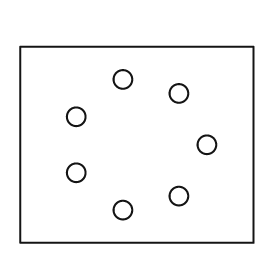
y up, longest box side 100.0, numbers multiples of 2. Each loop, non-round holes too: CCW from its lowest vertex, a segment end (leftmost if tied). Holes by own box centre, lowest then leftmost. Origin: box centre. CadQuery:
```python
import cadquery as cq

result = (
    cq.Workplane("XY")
    .moveTo(-50.0, -42.0)
    .lineTo(50.0, -42.0)
    .lineTo(50.0, 42.0)
    .lineTo(-50.0, 42.0)
    .close()
    .moveTo(-6.0, -28.0)
    .circle(4.0)
    .moveTo(18.0, -22.0)
    .circle(4.0)
    .moveTo(-26.0, -12.0)
    .circle(4.0)
    .moveTo(30.0, 0.0)
    .circle(4.0)
    .moveTo(-26.0, 12.0)
    .circle(4.0)
    .moveTo(18.0, 22.0)
    .circle(4.0)
    .moveTo(-6.0, 28.0)
    .circle(4.0)
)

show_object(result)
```